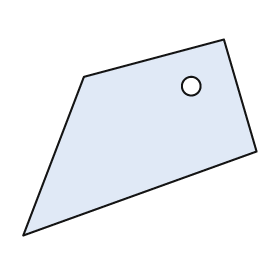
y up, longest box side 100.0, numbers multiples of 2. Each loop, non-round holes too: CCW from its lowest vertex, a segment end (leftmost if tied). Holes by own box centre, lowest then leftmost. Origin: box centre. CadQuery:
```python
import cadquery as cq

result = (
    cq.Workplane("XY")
    .moveTo(-50.0, -42.0)
    .lineTo(50.0, -6.0)
    .lineTo(36.0, 42.0)
    .lineTo(-24.0, 26.0)
    .close()
    .moveTo(22.0, 22.0)
    .circle(4.0)
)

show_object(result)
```